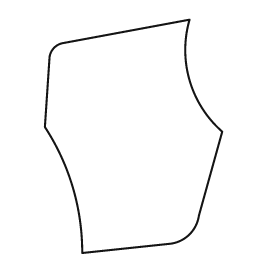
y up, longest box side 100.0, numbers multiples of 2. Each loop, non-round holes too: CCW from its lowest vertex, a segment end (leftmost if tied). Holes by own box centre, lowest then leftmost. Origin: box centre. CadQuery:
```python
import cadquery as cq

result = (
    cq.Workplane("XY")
    .moveTo(-22.0, -50.0)
    .lineTo(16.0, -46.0)
    .threePointArc((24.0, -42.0), (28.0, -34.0))
    .lineTo(38.0, 2.0)
    .threePointArc((24.0, 24.0), (24.0, 50.0))
    .lineTo(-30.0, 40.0)
    .threePointArc((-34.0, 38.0), (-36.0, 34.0))
    .lineTo(-38.0, 4.0)
    .threePointArc((-26.0, -22.0), (-22.0, -50.0))
    .close()
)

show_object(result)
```